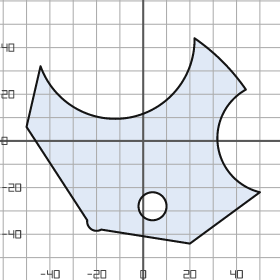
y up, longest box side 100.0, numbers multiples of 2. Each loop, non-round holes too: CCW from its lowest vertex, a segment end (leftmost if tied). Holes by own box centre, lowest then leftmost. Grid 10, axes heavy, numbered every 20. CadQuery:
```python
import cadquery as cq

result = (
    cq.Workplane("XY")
    .moveTo(20.0, -44.0)
    .lineTo(50.0, -22.0)
    .threePointArc((32.0, -2.0), (44.0, 22.0))
    .threePointArc((34.0, 34.0), (22.0, 44.0))
    .threePointArc((-6.0, 10.0), (-44.0, 32.0))
    .lineTo(-50.0, 6.0)
    .lineTo(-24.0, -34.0)
    .threePointArc((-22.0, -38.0), (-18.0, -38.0))
    .close()
    .moveTo(4.0, -28.0)
    .circle(6.0)
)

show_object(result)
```